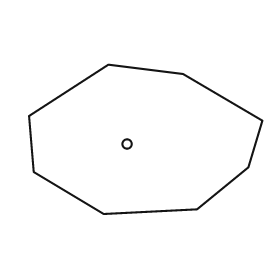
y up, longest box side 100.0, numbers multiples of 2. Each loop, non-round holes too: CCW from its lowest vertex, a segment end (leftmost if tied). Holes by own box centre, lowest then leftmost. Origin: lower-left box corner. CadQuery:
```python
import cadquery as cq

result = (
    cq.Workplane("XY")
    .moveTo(32.0, 0.0)
    .lineTo(72.0, 2.0)
    .lineTo(94.0, 20.0)
    .lineTo(100.0, 40.0)
    .lineTo(66.0, 60.0)
    .lineTo(34.0, 64.0)
    .lineTo(0.0, 42.0)
    .lineTo(2.0, 18.0)
    .close()
    .moveTo(42.0, 30.0)
    .circle(2.0)
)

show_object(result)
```